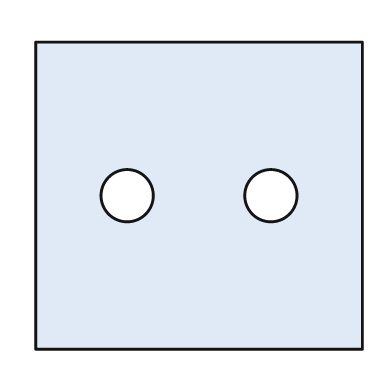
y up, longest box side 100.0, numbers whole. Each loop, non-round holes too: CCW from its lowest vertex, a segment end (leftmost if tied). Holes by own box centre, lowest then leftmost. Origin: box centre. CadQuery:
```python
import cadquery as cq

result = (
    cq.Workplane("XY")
    .moveTo(-50.0, -47.0)
    .lineTo(50.0, -47.0)
    .lineTo(50.0, 47.0)
    .lineTo(-50.0, 47.0)
    .close()
    .moveTo(-22.0, 0.0)
    .circle(8.0)
    .moveTo(22.0, 0.0)
    .circle(8.0)
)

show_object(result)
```